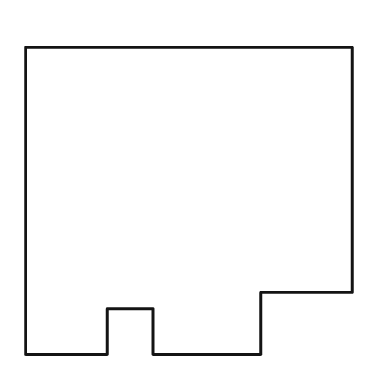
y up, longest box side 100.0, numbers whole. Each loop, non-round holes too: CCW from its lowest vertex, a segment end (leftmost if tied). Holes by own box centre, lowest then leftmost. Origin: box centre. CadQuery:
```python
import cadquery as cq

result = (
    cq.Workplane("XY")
    .moveTo(-50.0, -47.0)
    .lineTo(-25.0, -47.0)
    .lineTo(-25.0, -33.0)
    .lineTo(-11.0, -33.0)
    .lineTo(-11.0, -47.0)
    .lineTo(22.0, -47.0)
    .lineTo(22.0, -28.0)
    .lineTo(50.0, -28.0)
    .lineTo(50.0, 47.0)
    .lineTo(-50.0, 47.0)
    .close()
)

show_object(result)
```